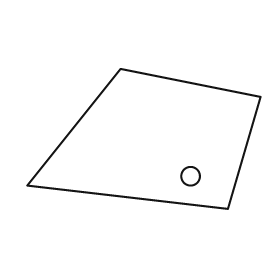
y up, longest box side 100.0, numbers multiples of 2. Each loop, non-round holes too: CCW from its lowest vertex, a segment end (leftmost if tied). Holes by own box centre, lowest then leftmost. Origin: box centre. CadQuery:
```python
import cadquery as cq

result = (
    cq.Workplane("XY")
    .moveTo(36.0, -30.0)
    .lineTo(50.0, 18.0)
    .lineTo(-10.0, 30.0)
    .lineTo(-50.0, -20.0)
    .close()
    .moveTo(20.0, -16.0)
    .circle(4.0)
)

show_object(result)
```